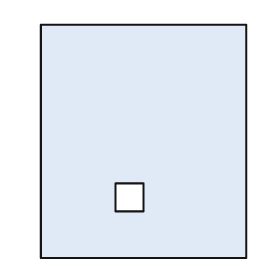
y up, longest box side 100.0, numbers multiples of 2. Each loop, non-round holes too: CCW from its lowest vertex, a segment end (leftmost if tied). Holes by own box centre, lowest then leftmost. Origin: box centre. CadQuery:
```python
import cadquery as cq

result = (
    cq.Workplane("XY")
    .moveTo(-44.0, -50.0)
    .lineTo(44.0, -50.0)
    .lineTo(44.0, 50.0)
    .lineTo(-44.0, 50.0)
    .close()
    .moveTo(-12.0, -30.0)
    .lineTo(0.0, -30.0)
    .lineTo(0.0, -18.0)
    .lineTo(-12.0, -18.0)
    .close()
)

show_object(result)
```